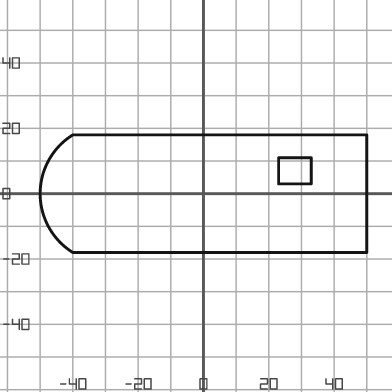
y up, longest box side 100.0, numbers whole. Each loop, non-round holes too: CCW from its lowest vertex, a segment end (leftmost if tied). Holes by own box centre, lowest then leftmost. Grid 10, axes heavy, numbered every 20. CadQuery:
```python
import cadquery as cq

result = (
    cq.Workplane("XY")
    .moveTo(-40.0, -18.0)
    .lineTo(50.0, -18.0)
    .lineTo(50.0, 18.0)
    .lineTo(-40.0, 18.0)
    .threePointArc((-50.0, 0.0), (-40.0, -18.0))
    .close()
    .moveTo(23.0, 3.0)
    .lineTo(33.0, 3.0)
    .lineTo(33.0, 11.0)
    .lineTo(23.0, 11.0)
    .close()
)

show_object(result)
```